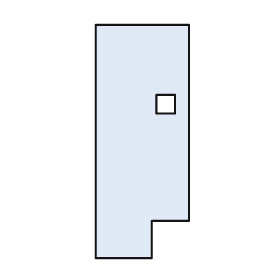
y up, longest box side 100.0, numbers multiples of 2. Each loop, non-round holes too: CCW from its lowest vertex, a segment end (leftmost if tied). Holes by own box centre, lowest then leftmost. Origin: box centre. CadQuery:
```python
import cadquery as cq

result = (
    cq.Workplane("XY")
    .moveTo(-20.0, -50.0)
    .lineTo(4.0, -50.0)
    .lineTo(4.0, -34.0)
    .lineTo(20.0, -34.0)
    .lineTo(20.0, 50.0)
    .lineTo(-20.0, 50.0)
    .close()
    .moveTo(6.0, 12.0)
    .lineTo(14.0, 12.0)
    .lineTo(14.0, 20.0)
    .lineTo(6.0, 20.0)
    .close()
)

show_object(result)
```